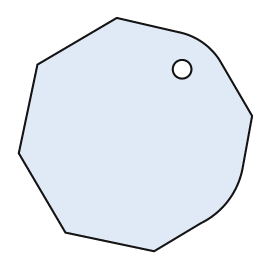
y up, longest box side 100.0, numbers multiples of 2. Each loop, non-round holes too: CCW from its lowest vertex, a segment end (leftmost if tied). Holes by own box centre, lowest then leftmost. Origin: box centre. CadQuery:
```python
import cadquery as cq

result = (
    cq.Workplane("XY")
    .moveTo(8.0, -50.0)
    .lineTo(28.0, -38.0)
    .threePointArc((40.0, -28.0), (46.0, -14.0))
    .lineTo(50.0, 8.0)
    .lineTo(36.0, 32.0)
    .threePointArc((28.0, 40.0), (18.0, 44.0))
    .lineTo(-8.0, 50.0)
    .lineTo(-42.0, 30.0)
    .lineTo(-50.0, -8.0)
    .lineTo(-30.0, -42.0)
    .close()
    .moveTo(20.0, 28.0)
    .circle(4.0)
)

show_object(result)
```